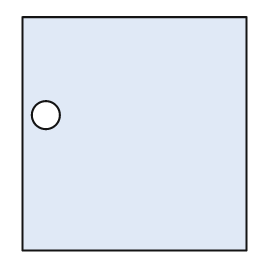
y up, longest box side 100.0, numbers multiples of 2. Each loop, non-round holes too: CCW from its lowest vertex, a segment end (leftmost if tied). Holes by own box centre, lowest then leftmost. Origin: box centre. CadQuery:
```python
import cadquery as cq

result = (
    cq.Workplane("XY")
    .moveTo(-48.0, -50.0)
    .lineTo(48.0, -50.0)
    .lineTo(48.0, 50.0)
    .lineTo(-48.0, 50.0)
    .close()
    .moveTo(-38.0, 8.0)
    .circle(6.0)
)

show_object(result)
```